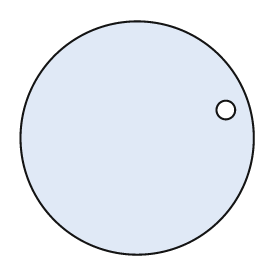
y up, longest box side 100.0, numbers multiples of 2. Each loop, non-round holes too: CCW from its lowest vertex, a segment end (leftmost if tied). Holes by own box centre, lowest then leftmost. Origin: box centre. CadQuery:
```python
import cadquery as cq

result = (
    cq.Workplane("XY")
    .moveTo(0.0, 0.0)
    .circle(50.0)
    .moveTo(38.0, 12.0)
    .circle(4.0)
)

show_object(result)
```